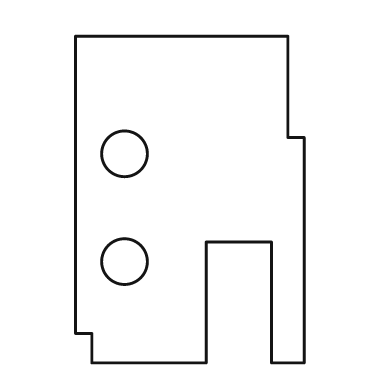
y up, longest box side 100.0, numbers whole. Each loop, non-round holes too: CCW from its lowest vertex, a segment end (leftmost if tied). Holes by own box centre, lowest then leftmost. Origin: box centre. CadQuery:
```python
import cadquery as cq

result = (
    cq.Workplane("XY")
    .moveTo(-30.0, -50.0)
    .lineTo(5.0, -50.0)
    .lineTo(5.0, -13.0)
    .lineTo(25.0, -13.0)
    .lineTo(25.0, -50.0)
    .lineTo(35.0, -50.0)
    .lineTo(35.0, 19.0)
    .lineTo(30.0, 19.0)
    .lineTo(30.0, 50.0)
    .lineTo(-35.0, 50.0)
    .lineTo(-35.0, -41.0)
    .lineTo(-30.0, -41.0)
    .close()
    .moveTo(-20.0, -19.0)
    .circle(7.0)
    .moveTo(-20.0, 14.0)
    .circle(7.0)
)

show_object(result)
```